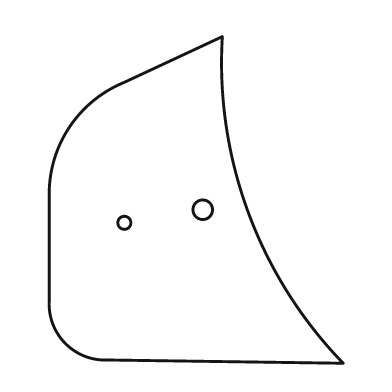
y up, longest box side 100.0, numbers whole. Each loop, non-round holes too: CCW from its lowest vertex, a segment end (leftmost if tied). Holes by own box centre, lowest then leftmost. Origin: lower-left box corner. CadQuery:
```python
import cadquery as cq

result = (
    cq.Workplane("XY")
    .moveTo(90.0, 0.0)
    .threePointArc((61.0, 46.0), (53.0, 100.0))
    .lineTo(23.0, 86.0)
    .threePointArc((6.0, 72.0), (0.0, 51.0))
    .lineTo(0.0, 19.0)
    .threePointArc((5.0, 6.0), (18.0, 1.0))
    .close()
    .moveTo(23.0, 43.0)
    .circle(2.0)
    .moveTo(47.0, 47.0)
    .circle(3.0)
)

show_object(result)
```